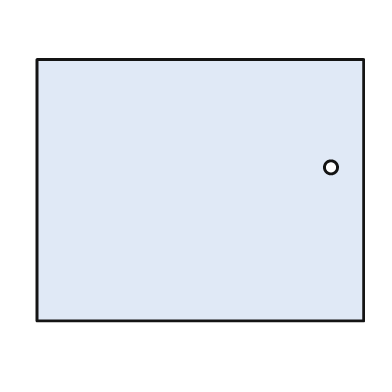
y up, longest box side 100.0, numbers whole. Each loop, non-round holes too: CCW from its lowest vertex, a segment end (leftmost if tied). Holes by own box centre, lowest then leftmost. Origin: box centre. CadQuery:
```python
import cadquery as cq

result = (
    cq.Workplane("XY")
    .moveTo(-50.0, -40.0)
    .lineTo(50.0, -40.0)
    .lineTo(50.0, 40.0)
    .lineTo(-50.0, 40.0)
    .close()
    .moveTo(40.0, 7.0)
    .circle(2.0)
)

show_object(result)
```